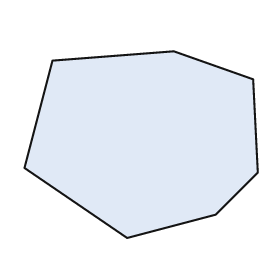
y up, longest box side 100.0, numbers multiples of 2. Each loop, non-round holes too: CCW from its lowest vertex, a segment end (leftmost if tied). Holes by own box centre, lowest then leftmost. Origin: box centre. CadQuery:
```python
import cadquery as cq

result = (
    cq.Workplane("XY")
    .moveTo(-6.0, -40.0)
    .lineTo(32.0, -30.0)
    .lineTo(50.0, -12.0)
    .lineTo(48.0, 28.0)
    .lineTo(14.0, 40.0)
    .lineTo(-38.0, 36.0)
    .lineTo(-50.0, -10.0)
    .close()
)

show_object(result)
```